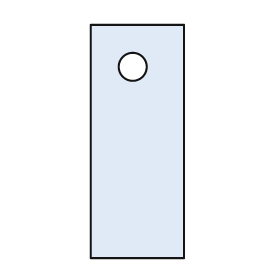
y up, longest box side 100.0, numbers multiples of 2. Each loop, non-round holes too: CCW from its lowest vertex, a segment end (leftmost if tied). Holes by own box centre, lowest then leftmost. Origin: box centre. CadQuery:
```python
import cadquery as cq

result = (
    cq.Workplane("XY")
    .moveTo(-20.0, -50.0)
    .lineTo(20.0, -50.0)
    .lineTo(20.0, 50.0)
    .lineTo(-20.0, 50.0)
    .close()
    .moveTo(-2.0, 32.0)
    .circle(6.0)
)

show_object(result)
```